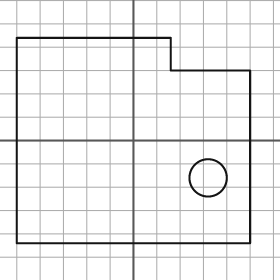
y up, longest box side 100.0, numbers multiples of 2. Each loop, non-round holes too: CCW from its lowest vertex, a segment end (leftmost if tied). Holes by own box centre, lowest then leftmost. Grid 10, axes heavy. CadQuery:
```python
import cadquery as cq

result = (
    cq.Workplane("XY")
    .moveTo(-50.0, -44.0)
    .lineTo(50.0, -44.0)
    .lineTo(50.0, 30.0)
    .lineTo(16.0, 30.0)
    .lineTo(16.0, 44.0)
    .lineTo(-50.0, 44.0)
    .close()
    .moveTo(32.0, -16.0)
    .circle(8.0)
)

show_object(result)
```